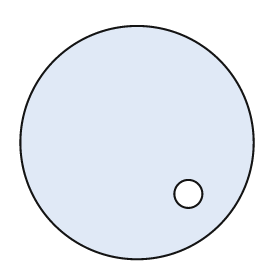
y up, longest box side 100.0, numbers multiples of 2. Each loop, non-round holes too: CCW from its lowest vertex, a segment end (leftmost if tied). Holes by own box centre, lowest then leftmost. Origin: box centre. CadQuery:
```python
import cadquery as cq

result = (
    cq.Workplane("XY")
    .moveTo(0.0, 0.0)
    .circle(50.0)
    .moveTo(22.0, -22.0)
    .circle(6.0)
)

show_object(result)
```